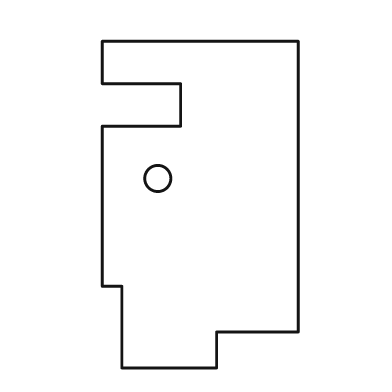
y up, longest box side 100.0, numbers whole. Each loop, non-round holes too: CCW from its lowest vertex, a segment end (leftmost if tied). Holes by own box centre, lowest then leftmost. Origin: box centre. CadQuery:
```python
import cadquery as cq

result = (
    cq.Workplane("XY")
    .moveTo(-24.0, -50.0)
    .lineTo(5.0, -50.0)
    .lineTo(5.0, -39.0)
    .lineTo(30.0, -39.0)
    .lineTo(30.0, 50.0)
    .lineTo(-30.0, 50.0)
    .lineTo(-30.0, 37.0)
    .lineTo(-6.0, 37.0)
    .lineTo(-6.0, 24.0)
    .lineTo(-30.0, 24.0)
    .lineTo(-30.0, -25.0)
    .lineTo(-24.0, -25.0)
    .close()
    .moveTo(-13.0, 8.0)
    .circle(4.0)
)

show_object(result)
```